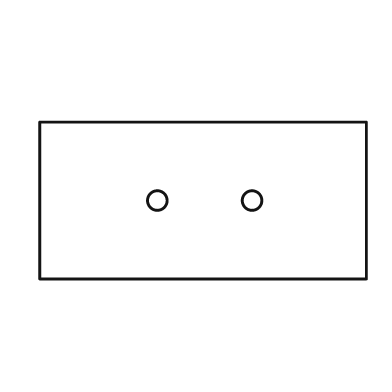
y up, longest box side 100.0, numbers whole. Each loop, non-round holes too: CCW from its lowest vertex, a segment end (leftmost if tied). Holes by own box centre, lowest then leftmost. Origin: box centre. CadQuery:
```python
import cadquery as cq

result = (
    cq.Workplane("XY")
    .moveTo(-50.0, -24.0)
    .lineTo(50.0, -24.0)
    .lineTo(50.0, 24.0)
    .lineTo(-50.0, 24.0)
    .close()
    .moveTo(-14.0, 0.0)
    .circle(3.0)
    .moveTo(15.0, 0.0)
    .circle(3.0)
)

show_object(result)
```